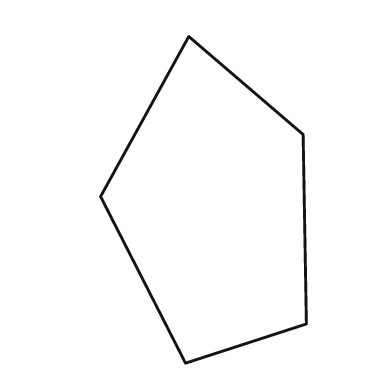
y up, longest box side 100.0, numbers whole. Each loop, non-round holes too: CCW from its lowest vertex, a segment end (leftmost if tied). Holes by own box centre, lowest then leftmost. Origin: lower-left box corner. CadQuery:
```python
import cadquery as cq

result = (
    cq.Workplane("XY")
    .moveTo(26.0, 0.0)
    .lineTo(63.0, 12.0)
    .lineTo(62.0, 70.0)
    .lineTo(27.0, 100.0)
    .lineTo(0.0, 51.0)
    .close()
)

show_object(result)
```